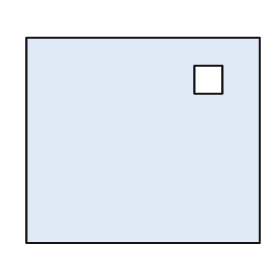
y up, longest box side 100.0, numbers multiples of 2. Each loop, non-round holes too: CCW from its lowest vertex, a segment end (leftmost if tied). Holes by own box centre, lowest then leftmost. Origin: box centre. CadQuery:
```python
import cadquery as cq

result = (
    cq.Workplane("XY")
    .moveTo(-50.0, -44.0)
    .lineTo(50.0, -44.0)
    .lineTo(50.0, 44.0)
    .lineTo(-50.0, 44.0)
    .close()
    .moveTo(22.0, 20.0)
    .lineTo(34.0, 20.0)
    .lineTo(34.0, 32.0)
    .lineTo(22.0, 32.0)
    .close()
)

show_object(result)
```